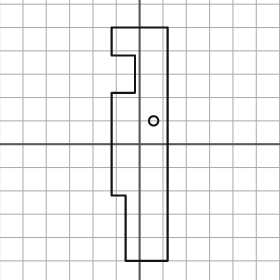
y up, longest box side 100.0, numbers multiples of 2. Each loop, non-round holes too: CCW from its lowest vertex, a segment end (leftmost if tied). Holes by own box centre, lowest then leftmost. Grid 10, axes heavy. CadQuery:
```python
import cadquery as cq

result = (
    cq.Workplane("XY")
    .moveTo(-6.0, -50.0)
    .lineTo(12.0, -50.0)
    .lineTo(12.0, 50.0)
    .lineTo(-12.0, 50.0)
    .lineTo(-12.0, 38.0)
    .lineTo(-2.0, 38.0)
    .lineTo(-2.0, 22.0)
    .lineTo(-12.0, 22.0)
    .lineTo(-12.0, -22.0)
    .lineTo(-6.0, -22.0)
    .close()
    .moveTo(6.0, 10.0)
    .circle(2.0)
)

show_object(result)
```